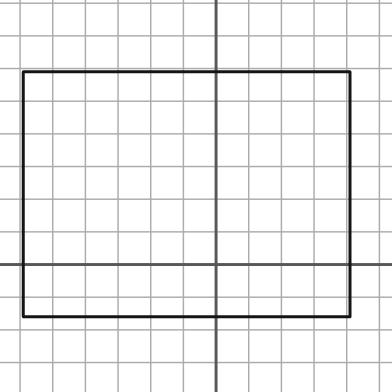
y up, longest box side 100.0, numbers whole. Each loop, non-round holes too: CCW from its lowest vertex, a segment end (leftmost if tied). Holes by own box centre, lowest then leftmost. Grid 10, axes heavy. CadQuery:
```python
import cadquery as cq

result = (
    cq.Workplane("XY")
    .moveTo(-59.0, -16.0)
    .lineTo(41.0, -16.0)
    .lineTo(41.0, 59.0)
    .lineTo(-59.0, 59.0)
    .close()
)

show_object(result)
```